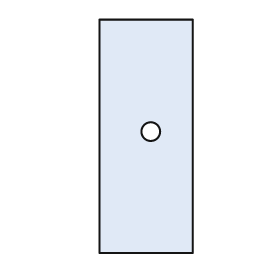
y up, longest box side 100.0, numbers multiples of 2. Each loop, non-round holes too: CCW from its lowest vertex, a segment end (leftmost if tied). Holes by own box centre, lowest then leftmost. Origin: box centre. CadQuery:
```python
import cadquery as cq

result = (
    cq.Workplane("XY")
    .moveTo(-20.0, -50.0)
    .lineTo(20.0, -50.0)
    .lineTo(20.0, 50.0)
    .lineTo(-20.0, 50.0)
    .close()
    .moveTo(2.0, 2.0)
    .circle(4.0)
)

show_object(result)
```